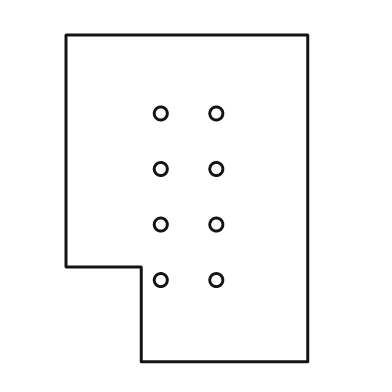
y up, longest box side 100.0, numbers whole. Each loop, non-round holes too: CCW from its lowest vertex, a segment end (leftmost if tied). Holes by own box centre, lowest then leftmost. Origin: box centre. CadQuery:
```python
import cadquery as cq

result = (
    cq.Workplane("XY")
    .moveTo(-14.0, -50.0)
    .lineTo(37.0, -50.0)
    .lineTo(37.0, 50.0)
    .lineTo(-37.0, 50.0)
    .lineTo(-37.0, -21.0)
    .lineTo(-14.0, -21.0)
    .close()
    .moveTo(-8.0, -25.0)
    .circle(2.0)
    .moveTo(9.0, -25.0)
    .circle(2.0)
    .moveTo(-8.0, -8.0)
    .circle(2.0)
    .moveTo(9.0, -8.0)
    .circle(2.0)
    .moveTo(-8.0, 9.0)
    .circle(2.0)
    .moveTo(9.0, 9.0)
    .circle(2.0)
    .moveTo(-8.0, 26.0)
    .circle(2.0)
    .moveTo(9.0, 26.0)
    .circle(2.0)
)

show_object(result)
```